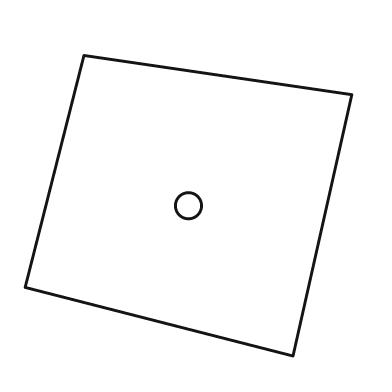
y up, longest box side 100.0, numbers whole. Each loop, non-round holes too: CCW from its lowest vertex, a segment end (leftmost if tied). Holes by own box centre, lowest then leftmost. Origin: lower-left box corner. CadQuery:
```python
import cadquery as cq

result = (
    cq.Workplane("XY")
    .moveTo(82.0, 0.0)
    .lineTo(100.0, 80.0)
    .lineTo(18.0, 92.0)
    .lineTo(0.0, 21.0)
    .close()
    .moveTo(50.0, 46.0)
    .circle(4.0)
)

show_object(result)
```